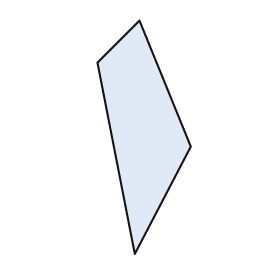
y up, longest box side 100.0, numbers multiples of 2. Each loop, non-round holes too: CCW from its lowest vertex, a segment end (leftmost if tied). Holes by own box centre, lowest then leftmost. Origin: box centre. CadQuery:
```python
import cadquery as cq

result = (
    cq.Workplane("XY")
    .moveTo(-4.0, -50.0)
    .lineTo(20.0, -4.0)
    .lineTo(-2.0, 50.0)
    .lineTo(-20.0, 32.0)
    .close()
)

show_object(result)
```